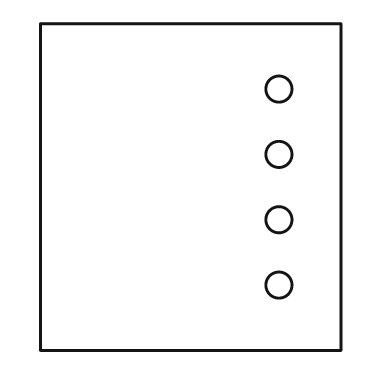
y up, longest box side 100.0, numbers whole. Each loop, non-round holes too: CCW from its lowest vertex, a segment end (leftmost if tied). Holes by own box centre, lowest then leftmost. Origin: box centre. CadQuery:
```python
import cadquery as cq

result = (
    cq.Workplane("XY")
    .moveTo(-46.0, -50.0)
    .lineTo(46.0, -50.0)
    .lineTo(46.0, 50.0)
    .lineTo(-46.0, 50.0)
    .close()
    .moveTo(27.0, -30.0)
    .circle(4.0)
    .moveTo(27.0, -10.0)
    .circle(4.0)
    .moveTo(27.0, 10.0)
    .circle(4.0)
    .moveTo(27.0, 30.0)
    .circle(4.0)
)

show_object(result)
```